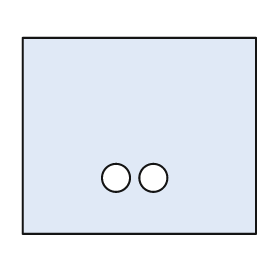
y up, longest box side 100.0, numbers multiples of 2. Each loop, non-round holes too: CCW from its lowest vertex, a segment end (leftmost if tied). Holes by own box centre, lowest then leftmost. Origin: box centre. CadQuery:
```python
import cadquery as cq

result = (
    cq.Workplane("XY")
    .moveTo(-50.0, -42.0)
    .lineTo(50.0, -42.0)
    .lineTo(50.0, 42.0)
    .lineTo(-50.0, 42.0)
    .close()
    .moveTo(-10.0, -18.0)
    .circle(6.0)
    .moveTo(6.0, -18.0)
    .circle(6.0)
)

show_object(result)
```